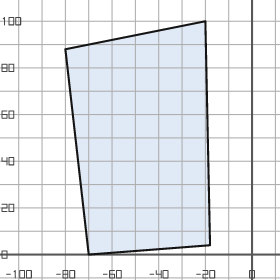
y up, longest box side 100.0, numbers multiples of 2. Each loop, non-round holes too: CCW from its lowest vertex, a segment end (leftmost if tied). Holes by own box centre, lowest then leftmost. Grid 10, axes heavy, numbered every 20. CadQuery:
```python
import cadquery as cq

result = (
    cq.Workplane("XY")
    .moveTo(-70.0, 0.0)
    .lineTo(-18.0, 4.0)
    .lineTo(-20.0, 100.0)
    .lineTo(-80.0, 88.0)
    .close()
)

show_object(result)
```